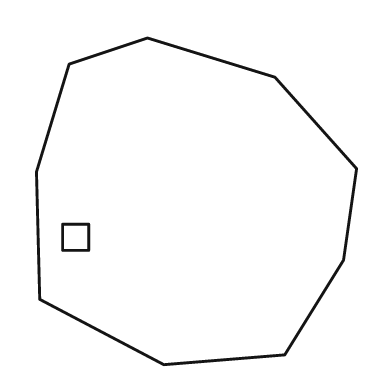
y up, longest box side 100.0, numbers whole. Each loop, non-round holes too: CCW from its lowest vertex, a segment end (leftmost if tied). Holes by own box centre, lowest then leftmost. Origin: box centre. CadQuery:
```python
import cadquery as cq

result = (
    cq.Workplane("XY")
    .moveTo(-10.0, -50.0)
    .lineTo(27.0, -47.0)
    .lineTo(45.0, -18.0)
    .lineTo(49.0, 10.0)
    .lineTo(24.0, 38.0)
    .lineTo(-15.0, 50.0)
    .lineTo(-39.0, 42.0)
    .lineTo(-49.0, 9.0)
    .lineTo(-48.0, -30.0)
    .close()
    .moveTo(-41.0, -15.0)
    .lineTo(-33.0, -15.0)
    .lineTo(-33.0, -7.0)
    .lineTo(-41.0, -7.0)
    .close()
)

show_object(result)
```